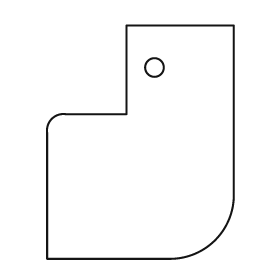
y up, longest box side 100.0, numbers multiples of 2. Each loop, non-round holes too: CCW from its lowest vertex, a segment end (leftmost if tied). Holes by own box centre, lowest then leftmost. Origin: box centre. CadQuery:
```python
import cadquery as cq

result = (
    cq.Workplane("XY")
    .moveTo(-40.0, -50.0)
    .lineTo(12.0, -50.0)
    .threePointArc((32.0, -42.0), (40.0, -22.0))
    .lineTo(40.0, 50.0)
    .lineTo(-6.0, 50.0)
    .lineTo(-6.0, 12.0)
    .lineTo(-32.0, 12.0)
    .threePointArc((-38.0, 10.0), (-40.0, 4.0))
    .close()
    .moveTo(6.0, 32.0)
    .circle(4.0)
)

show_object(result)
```